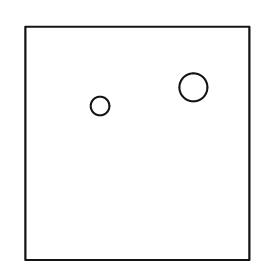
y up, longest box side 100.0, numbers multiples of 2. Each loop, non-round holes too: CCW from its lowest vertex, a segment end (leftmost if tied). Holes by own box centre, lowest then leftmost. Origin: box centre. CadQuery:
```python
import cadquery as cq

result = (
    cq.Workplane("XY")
    .moveTo(-48.0, -50.0)
    .lineTo(48.0, -50.0)
    .lineTo(48.0, 50.0)
    .lineTo(-48.0, 50.0)
    .close()
    .moveTo(-16.0, 16.0)
    .circle(4.0)
    .moveTo(24.0, 24.0)
    .circle(6.0)
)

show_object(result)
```